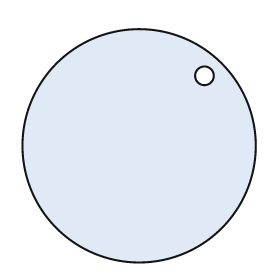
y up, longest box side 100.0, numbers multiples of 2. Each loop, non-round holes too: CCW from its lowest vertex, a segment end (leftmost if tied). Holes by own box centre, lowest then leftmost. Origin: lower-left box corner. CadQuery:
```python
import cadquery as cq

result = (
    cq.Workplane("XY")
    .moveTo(50.0, 50.0)
    .circle(50.0)
    .moveTo(78.0, 80.0)
    .circle(4.0)
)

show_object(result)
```